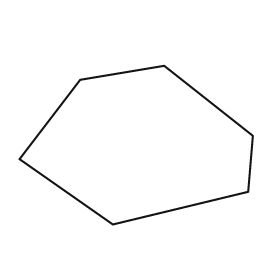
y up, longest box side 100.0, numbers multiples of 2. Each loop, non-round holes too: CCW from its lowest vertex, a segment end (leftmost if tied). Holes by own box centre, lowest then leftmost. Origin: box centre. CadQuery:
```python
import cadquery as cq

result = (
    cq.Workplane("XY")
    .moveTo(-10.0, -34.0)
    .lineTo(48.0, -20.0)
    .lineTo(50.0, 4.0)
    .lineTo(12.0, 34.0)
    .lineTo(-24.0, 28.0)
    .lineTo(-50.0, -6.0)
    .close()
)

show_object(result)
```